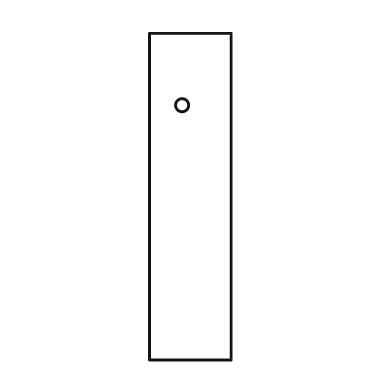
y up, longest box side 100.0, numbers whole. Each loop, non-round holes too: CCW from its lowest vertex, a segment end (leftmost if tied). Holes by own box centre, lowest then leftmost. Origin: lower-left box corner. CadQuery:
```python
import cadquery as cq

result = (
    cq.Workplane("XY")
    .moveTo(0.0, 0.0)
    .lineTo(25.0, 0.0)
    .lineTo(25.0, 100.0)
    .lineTo(0.0, 100.0)
    .close()
    .moveTo(10.0, 78.0)
    .circle(2.0)
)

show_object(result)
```